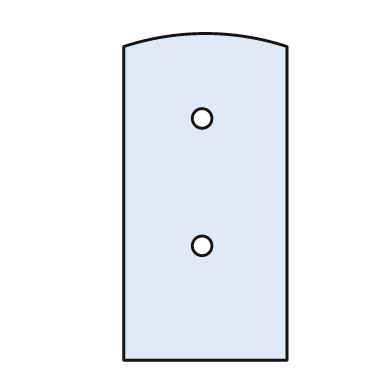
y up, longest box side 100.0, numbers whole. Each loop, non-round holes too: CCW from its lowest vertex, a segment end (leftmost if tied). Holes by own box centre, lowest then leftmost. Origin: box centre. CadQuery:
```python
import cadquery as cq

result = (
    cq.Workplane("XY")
    .moveTo(-25.0, -50.0)
    .lineTo(25.0, -50.0)
    .lineTo(25.0, 46.0)
    .threePointArc((0.0, 50.0), (-25.0, 46.0))
    .close()
    .moveTo(-1.0, -15.0)
    .circle(3.0)
    .moveTo(-1.0, 24.0)
    .circle(3.0)
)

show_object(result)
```